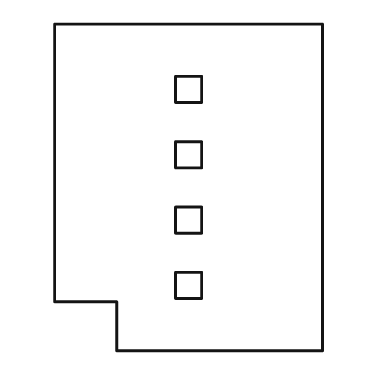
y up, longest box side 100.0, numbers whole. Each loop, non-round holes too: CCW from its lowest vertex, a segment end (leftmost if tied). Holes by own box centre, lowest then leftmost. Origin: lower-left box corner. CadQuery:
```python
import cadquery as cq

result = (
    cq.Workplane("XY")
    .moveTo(19.0, 0.0)
    .lineTo(82.0, 0.0)
    .lineTo(82.0, 100.0)
    .lineTo(0.0, 100.0)
    .lineTo(0.0, 15.0)
    .lineTo(19.0, 15.0)
    .close()
    .moveTo(37.0, 16.0)
    .lineTo(45.0, 16.0)
    .lineTo(45.0, 24.0)
    .lineTo(37.0, 24.0)
    .close()
    .moveTo(37.0, 36.0)
    .lineTo(45.0, 36.0)
    .lineTo(45.0, 44.0)
    .lineTo(37.0, 44.0)
    .close()
    .moveTo(37.0, 56.0)
    .lineTo(45.0, 56.0)
    .lineTo(45.0, 64.0)
    .lineTo(37.0, 64.0)
    .close()
    .moveTo(37.0, 76.0)
    .lineTo(45.0, 76.0)
    .lineTo(45.0, 84.0)
    .lineTo(37.0, 84.0)
    .close()
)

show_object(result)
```